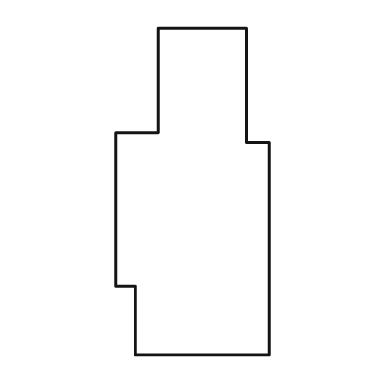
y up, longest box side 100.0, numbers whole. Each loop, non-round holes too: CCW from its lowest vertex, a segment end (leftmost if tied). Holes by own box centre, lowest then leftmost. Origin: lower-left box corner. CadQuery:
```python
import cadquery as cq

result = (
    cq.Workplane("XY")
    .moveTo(6.0, 0.0)
    .lineTo(47.0, 0.0)
    .lineTo(47.0, 65.0)
    .lineTo(40.0, 65.0)
    .lineTo(40.0, 100.0)
    .lineTo(13.0, 100.0)
    .lineTo(13.0, 68.0)
    .lineTo(0.0, 68.0)
    .lineTo(0.0, 21.0)
    .lineTo(6.0, 21.0)
    .close()
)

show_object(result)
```